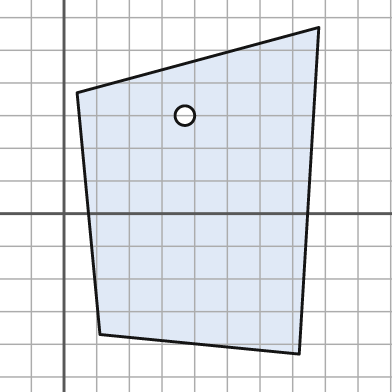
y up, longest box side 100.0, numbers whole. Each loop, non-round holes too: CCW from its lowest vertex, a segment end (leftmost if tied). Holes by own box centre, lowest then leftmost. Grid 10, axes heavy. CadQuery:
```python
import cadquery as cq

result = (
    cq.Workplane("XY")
    .moveTo(72.0, -43.0)
    .lineTo(78.0, 57.0)
    .lineTo(4.0, 37.0)
    .lineTo(11.0, -37.0)
    .close()
    .moveTo(37.0, 30.0)
    .circle(3.0)
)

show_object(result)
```